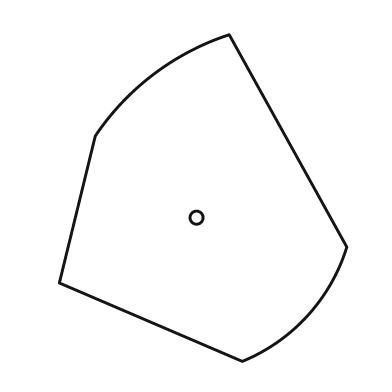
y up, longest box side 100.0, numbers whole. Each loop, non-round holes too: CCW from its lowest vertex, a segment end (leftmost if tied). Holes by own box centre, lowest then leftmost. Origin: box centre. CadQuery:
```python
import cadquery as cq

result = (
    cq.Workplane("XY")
    .moveTo(12.0, -50.0)
    .threePointArc((32.0, -36.0), (44.0, -15.0))
    .lineTo(8.0, 50.0)
    .threePointArc((-15.0, 38.0), (-33.0, 19.0))
    .lineTo(-44.0, -26.0)
    .close()
    .moveTo(-2.0, -6.0)
    .circle(2.0)
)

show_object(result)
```